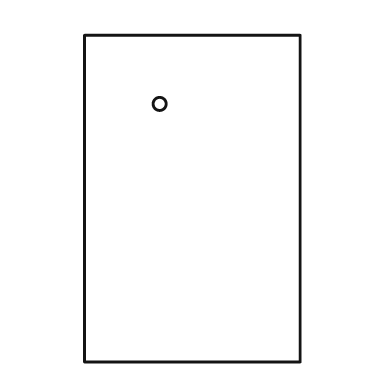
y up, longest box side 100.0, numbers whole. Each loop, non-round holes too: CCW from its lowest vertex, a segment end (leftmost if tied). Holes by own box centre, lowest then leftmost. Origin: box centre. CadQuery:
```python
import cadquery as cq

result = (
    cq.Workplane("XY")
    .moveTo(-33.0, -50.0)
    .lineTo(33.0, -50.0)
    .lineTo(33.0, 50.0)
    .lineTo(-33.0, 50.0)
    .close()
    .moveTo(-10.0, 29.0)
    .circle(2.0)
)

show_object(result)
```